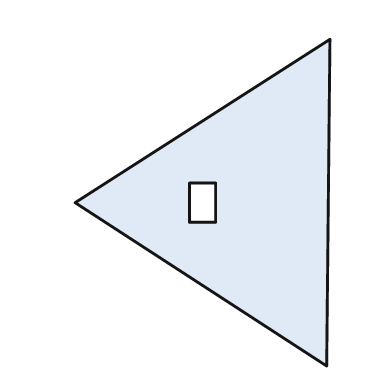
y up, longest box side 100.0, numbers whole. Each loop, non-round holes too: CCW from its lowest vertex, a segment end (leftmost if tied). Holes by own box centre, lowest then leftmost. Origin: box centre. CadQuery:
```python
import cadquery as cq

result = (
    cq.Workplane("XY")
    .moveTo(38.0, -50.0)
    .lineTo(39.0, 50.0)
    .lineTo(-39.0, 0.0)
    .close()
    .moveTo(-4.0, -6.0)
    .lineTo(4.0, -6.0)
    .lineTo(4.0, 6.0)
    .lineTo(-4.0, 6.0)
    .close()
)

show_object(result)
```